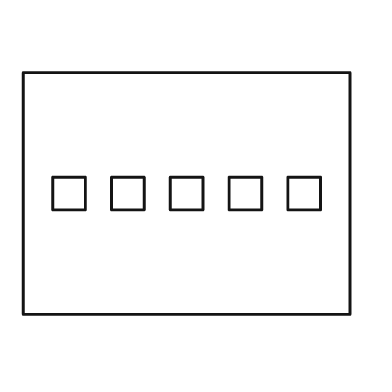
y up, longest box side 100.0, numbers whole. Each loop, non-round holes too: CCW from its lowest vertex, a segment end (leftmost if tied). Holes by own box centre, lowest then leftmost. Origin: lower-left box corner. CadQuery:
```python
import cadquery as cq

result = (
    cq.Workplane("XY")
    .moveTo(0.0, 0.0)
    .lineTo(100.0, 0.0)
    .lineTo(100.0, 74.0)
    .lineTo(0.0, 74.0)
    .close()
    .moveTo(9.0, 32.0)
    .lineTo(19.0, 32.0)
    .lineTo(19.0, 42.0)
    .lineTo(9.0, 42.0)
    .close()
    .moveTo(27.0, 32.0)
    .lineTo(37.0, 32.0)
    .lineTo(37.0, 42.0)
    .lineTo(27.0, 42.0)
    .close()
    .moveTo(45.0, 32.0)
    .lineTo(55.0, 32.0)
    .lineTo(55.0, 42.0)
    .lineTo(45.0, 42.0)
    .close()
    .moveTo(63.0, 32.0)
    .lineTo(73.0, 32.0)
    .lineTo(73.0, 42.0)
    .lineTo(63.0, 42.0)
    .close()
    .moveTo(81.0, 32.0)
    .lineTo(91.0, 32.0)
    .lineTo(91.0, 42.0)
    .lineTo(81.0, 42.0)
    .close()
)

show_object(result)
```